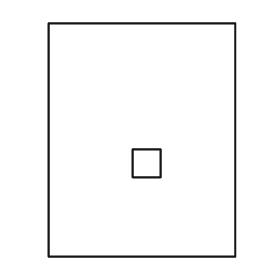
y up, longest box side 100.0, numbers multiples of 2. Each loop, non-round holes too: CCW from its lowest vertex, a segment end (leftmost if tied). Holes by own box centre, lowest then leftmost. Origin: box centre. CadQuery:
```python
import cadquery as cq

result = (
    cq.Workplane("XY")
    .moveTo(-40.0, -50.0)
    .lineTo(40.0, -50.0)
    .lineTo(40.0, 50.0)
    .lineTo(-40.0, 50.0)
    .close()
    .moveTo(-4.0, -16.0)
    .lineTo(8.0, -16.0)
    .lineTo(8.0, -4.0)
    .lineTo(-4.0, -4.0)
    .close()
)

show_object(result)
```